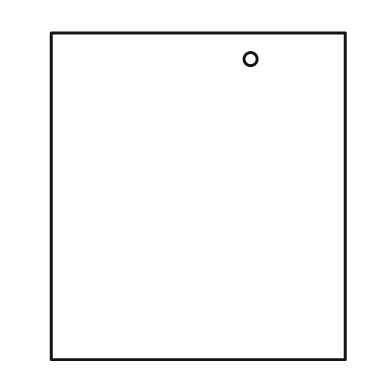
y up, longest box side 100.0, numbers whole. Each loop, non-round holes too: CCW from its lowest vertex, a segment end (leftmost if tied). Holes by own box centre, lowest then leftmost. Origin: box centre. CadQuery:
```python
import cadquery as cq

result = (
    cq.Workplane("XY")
    .moveTo(-45.0, -50.0)
    .lineTo(45.0, -50.0)
    .lineTo(45.0, 50.0)
    .lineTo(-45.0, 50.0)
    .close()
    .moveTo(16.0, 42.0)
    .circle(2.0)
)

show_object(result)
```